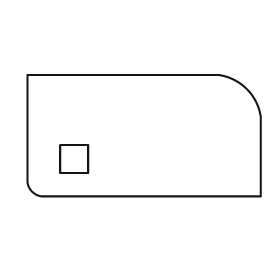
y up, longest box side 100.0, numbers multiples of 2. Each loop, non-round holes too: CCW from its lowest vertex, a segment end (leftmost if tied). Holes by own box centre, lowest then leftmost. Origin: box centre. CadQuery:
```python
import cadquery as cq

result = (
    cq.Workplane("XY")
    .moveTo(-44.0, -26.0)
    .lineTo(50.0, -26.0)
    .lineTo(50.0, 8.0)
    .threePointArc((44.0, 20.0), (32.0, 26.0))
    .lineTo(-50.0, 26.0)
    .lineTo(-50.0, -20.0)
    .threePointArc((-48.0, -24.0), (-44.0, -26.0))
    .close()
    .moveTo(-36.0, -16.0)
    .lineTo(-24.0, -16.0)
    .lineTo(-24.0, -4.0)
    .lineTo(-36.0, -4.0)
    .close()
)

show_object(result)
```